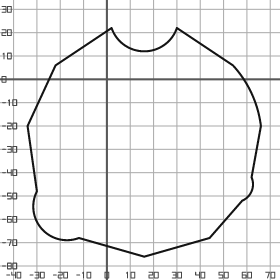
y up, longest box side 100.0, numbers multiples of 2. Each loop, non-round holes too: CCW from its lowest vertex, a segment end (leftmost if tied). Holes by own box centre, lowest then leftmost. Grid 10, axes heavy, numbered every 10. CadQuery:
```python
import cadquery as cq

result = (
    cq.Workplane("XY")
    .moveTo(16.0, -76.0)
    .lineTo(44.0, -68.0)
    .lineTo(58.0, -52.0)
    .threePointArc((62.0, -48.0), (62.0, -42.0))
    .lineTo(66.0, -20.0)
    .threePointArc((62.0, -6.0), (54.0, 6.0))
    .lineTo(30.0, 22.0)
    .threePointArc((16.0, 12.0), (2.0, 22.0))
    .lineTo(-22.0, 6.0)
    .lineTo(-34.0, -20.0)
    .lineTo(-30.0, -48.0)
    .threePointArc((-28.0, -64.0), (-12.0, -68.0))
    .close()
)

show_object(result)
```